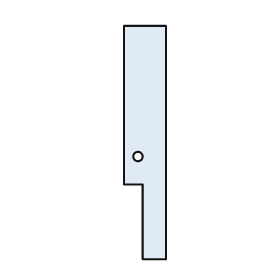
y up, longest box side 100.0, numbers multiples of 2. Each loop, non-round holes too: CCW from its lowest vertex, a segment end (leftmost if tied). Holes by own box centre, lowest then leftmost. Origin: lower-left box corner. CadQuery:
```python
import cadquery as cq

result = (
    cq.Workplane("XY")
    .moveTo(8.0, 0.0)
    .lineTo(18.0, 0.0)
    .lineTo(18.0, 100.0)
    .lineTo(0.0, 100.0)
    .lineTo(0.0, 32.0)
    .lineTo(8.0, 32.0)
    .close()
    .moveTo(6.0, 44.0)
    .circle(2.0)
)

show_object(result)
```